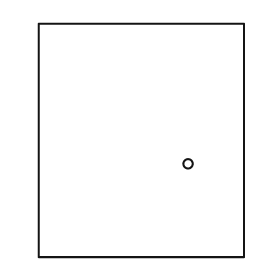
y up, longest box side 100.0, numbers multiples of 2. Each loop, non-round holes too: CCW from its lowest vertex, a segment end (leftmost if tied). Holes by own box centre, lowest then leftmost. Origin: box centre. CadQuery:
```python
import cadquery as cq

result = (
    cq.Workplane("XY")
    .moveTo(-44.0, -50.0)
    .lineTo(44.0, -50.0)
    .lineTo(44.0, 50.0)
    .lineTo(-44.0, 50.0)
    .close()
    .moveTo(20.0, -10.0)
    .circle(2.0)
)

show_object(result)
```